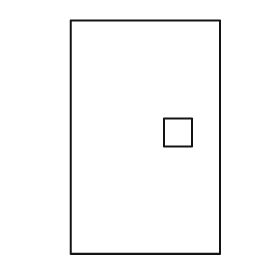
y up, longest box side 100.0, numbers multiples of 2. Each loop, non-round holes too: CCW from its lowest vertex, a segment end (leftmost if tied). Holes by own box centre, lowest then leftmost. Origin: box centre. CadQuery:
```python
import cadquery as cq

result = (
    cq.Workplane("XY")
    .moveTo(-32.0, -50.0)
    .lineTo(32.0, -50.0)
    .lineTo(32.0, 50.0)
    .lineTo(-32.0, 50.0)
    .close()
    .moveTo(8.0, -4.0)
    .lineTo(20.0, -4.0)
    .lineTo(20.0, 8.0)
    .lineTo(8.0, 8.0)
    .close()
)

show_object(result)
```